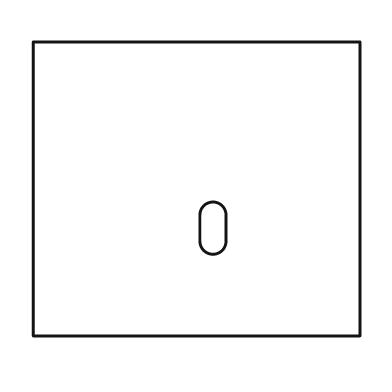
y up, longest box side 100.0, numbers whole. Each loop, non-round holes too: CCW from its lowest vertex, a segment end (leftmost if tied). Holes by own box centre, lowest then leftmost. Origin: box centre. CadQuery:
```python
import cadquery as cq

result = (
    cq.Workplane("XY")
    .moveTo(-50.0, -45.0)
    .lineTo(50.0, -45.0)
    .lineTo(50.0, 45.0)
    .lineTo(-50.0, 45.0)
    .close()
    .moveTo(1.0, -16.0)
    .threePointArc((5.0, -20.0), (9.0, -16.0))
    .lineTo(9.0, -8.0)
    .threePointArc((5.0, -4.0), (1.0, -8.0))
    .close()
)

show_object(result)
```